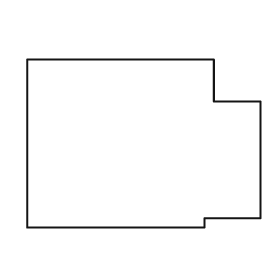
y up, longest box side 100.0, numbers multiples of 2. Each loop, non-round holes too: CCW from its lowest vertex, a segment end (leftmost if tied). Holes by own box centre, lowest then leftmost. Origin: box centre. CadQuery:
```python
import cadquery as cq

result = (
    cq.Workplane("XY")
    .moveTo(-50.0, -36.0)
    .lineTo(26.0, -36.0)
    .lineTo(26.0, -32.0)
    .lineTo(50.0, -32.0)
    .lineTo(50.0, 18.0)
    .lineTo(30.0, 18.0)
    .lineTo(30.0, 36.0)
    .lineTo(-50.0, 36.0)
    .close()
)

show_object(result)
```